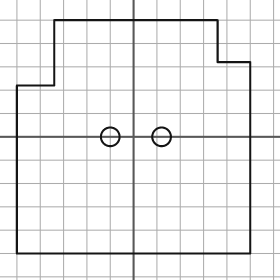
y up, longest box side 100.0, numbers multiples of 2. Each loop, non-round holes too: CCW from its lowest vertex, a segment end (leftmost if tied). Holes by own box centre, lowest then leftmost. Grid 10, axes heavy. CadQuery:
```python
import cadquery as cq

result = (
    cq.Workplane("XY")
    .moveTo(-50.0, -50.0)
    .lineTo(50.0, -50.0)
    .lineTo(50.0, 32.0)
    .lineTo(36.0, 32.0)
    .lineTo(36.0, 50.0)
    .lineTo(-34.0, 50.0)
    .lineTo(-34.0, 22.0)
    .lineTo(-50.0, 22.0)
    .close()
    .moveTo(-10.0, 0.0)
    .circle(4.0)
    .moveTo(12.0, 0.0)
    .circle(4.0)
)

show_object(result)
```